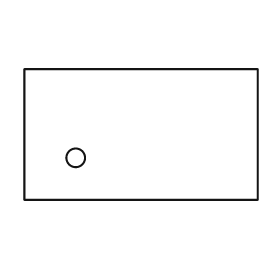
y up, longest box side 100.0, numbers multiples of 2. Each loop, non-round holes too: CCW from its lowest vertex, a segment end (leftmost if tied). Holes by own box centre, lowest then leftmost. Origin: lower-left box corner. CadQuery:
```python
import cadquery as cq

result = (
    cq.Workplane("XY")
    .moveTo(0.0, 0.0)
    .lineTo(100.0, 0.0)
    .lineTo(100.0, 56.0)
    .lineTo(0.0, 56.0)
    .close()
    .moveTo(22.0, 18.0)
    .circle(4.0)
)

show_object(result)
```